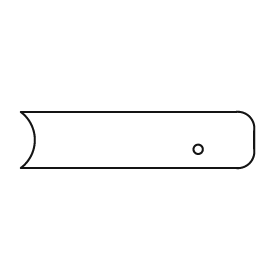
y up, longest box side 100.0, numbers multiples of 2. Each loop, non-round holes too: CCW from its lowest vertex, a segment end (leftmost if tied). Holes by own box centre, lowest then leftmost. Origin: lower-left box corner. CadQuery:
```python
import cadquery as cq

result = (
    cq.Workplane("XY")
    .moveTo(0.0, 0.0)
    .lineTo(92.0, 0.0)
    .threePointArc((98.0, 2.0), (100.0, 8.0))
    .lineTo(100.0, 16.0)
    .threePointArc((98.0, 22.0), (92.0, 24.0))
    .lineTo(0.0, 24.0)
    .threePointArc((6.0, 12.0), (0.0, 0.0))
    .close()
    .moveTo(76.0, 8.0)
    .circle(2.0)
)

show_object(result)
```